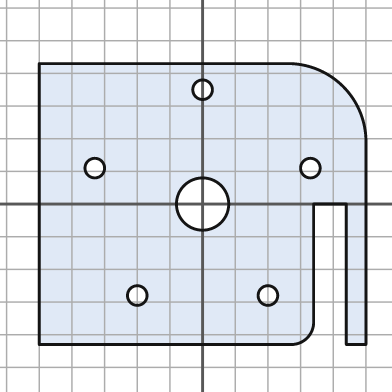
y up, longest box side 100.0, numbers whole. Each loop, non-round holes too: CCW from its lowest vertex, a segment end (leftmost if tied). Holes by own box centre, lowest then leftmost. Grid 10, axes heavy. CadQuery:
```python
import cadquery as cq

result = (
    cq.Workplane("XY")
    .moveTo(-50.0, -43.0)
    .lineTo(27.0, -43.0)
    .threePointArc((32.0, -41.0), (34.0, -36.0))
    .lineTo(34.0, 0.0)
    .lineTo(44.0, 0.0)
    .lineTo(44.0, -43.0)
    .lineTo(50.0, -43.0)
    .lineTo(50.0, 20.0)
    .threePointArc((43.0, 36.0), (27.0, 43.0))
    .lineTo(-50.0, 43.0)
    .close()
    .moveTo(-20.0, -28.0)
    .circle(3.0)
    .moveTo(20.0, -28.0)
    .circle(3.0)
    .moveTo(0.0, 0.0)
    .circle(8.0)
    .moveTo(-33.0, 11.0)
    .circle(3.0)
    .moveTo(33.0, 11.0)
    .circle(3.0)
    .moveTo(0.0, 35.0)
    .circle(3.0)
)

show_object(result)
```